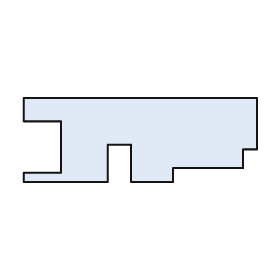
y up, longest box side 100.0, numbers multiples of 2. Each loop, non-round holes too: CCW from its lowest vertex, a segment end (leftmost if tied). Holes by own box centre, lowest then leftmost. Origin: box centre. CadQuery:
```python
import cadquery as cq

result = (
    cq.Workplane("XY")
    .moveTo(-50.0, -18.0)
    .lineTo(-14.0, -18.0)
    .lineTo(-14.0, -2.0)
    .lineTo(-4.0, -2.0)
    .lineTo(-4.0, -18.0)
    .lineTo(14.0, -18.0)
    .lineTo(14.0, -12.0)
    .lineTo(44.0, -12.0)
    .lineTo(44.0, -4.0)
    .lineTo(50.0, -4.0)
    .lineTo(50.0, 18.0)
    .lineTo(-50.0, 18.0)
    .lineTo(-50.0, 8.0)
    .lineTo(-34.0, 8.0)
    .lineTo(-34.0, -14.0)
    .lineTo(-50.0, -14.0)
    .close()
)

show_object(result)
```